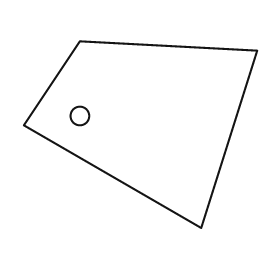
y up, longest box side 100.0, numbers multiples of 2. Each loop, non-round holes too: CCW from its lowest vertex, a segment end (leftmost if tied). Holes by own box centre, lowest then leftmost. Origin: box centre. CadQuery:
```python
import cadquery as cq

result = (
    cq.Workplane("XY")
    .moveTo(26.0, -40.0)
    .lineTo(50.0, 36.0)
    .lineTo(-26.0, 40.0)
    .lineTo(-50.0, 4.0)
    .close()
    .moveTo(-26.0, 8.0)
    .circle(4.0)
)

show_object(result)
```